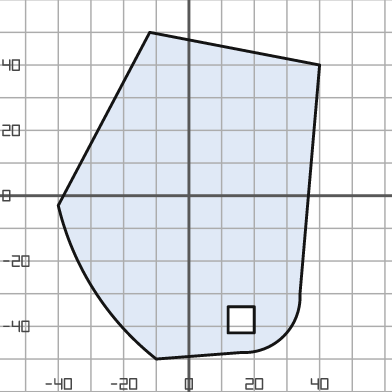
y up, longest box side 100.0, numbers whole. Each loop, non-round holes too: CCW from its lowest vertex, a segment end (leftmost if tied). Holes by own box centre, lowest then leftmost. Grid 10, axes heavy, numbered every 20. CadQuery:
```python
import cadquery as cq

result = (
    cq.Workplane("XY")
    .moveTo(-10.0, -50.0)
    .lineTo(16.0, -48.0)
    .threePointArc((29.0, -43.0), (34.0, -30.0))
    .lineTo(40.0, 40.0)
    .lineTo(-12.0, 50.0)
    .lineTo(-40.0, -3.0)
    .threePointArc((-29.0, -29.0), (-10.0, -50.0))
    .close()
    .moveTo(12.0, -42.0)
    .lineTo(20.0, -42.0)
    .lineTo(20.0, -34.0)
    .lineTo(12.0, -34.0)
    .close()
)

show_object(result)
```